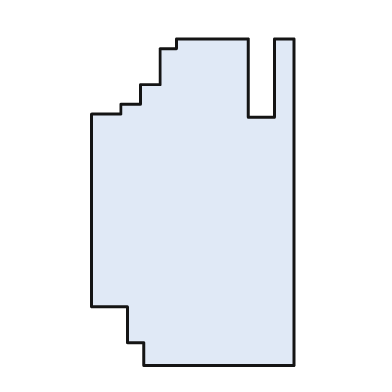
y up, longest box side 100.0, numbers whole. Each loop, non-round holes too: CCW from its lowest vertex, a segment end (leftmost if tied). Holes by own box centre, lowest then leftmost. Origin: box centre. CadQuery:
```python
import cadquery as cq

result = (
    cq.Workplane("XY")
    .moveTo(-15.0, -50.0)
    .lineTo(31.0, -50.0)
    .lineTo(31.0, 50.0)
    .lineTo(25.0, 50.0)
    .lineTo(25.0, 26.0)
    .lineTo(17.0, 26.0)
    .lineTo(17.0, 50.0)
    .lineTo(-5.0, 50.0)
    .lineTo(-5.0, 47.0)
    .lineTo(-10.0, 47.0)
    .lineTo(-10.0, 36.0)
    .lineTo(-16.0, 36.0)
    .lineTo(-16.0, 30.0)
    .lineTo(-22.0, 30.0)
    .lineTo(-22.0, 27.0)
    .lineTo(-31.0, 27.0)
    .lineTo(-31.0, -32.0)
    .lineTo(-20.0, -32.0)
    .lineTo(-20.0, -43.0)
    .lineTo(-15.0, -43.0)
    .close()
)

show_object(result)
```